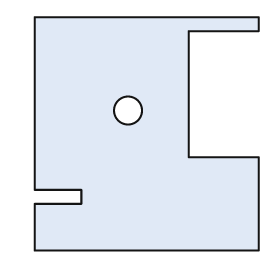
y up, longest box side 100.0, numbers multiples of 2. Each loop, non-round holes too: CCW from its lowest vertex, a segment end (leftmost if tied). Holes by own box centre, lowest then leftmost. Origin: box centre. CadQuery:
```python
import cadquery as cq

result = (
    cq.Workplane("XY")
    .moveTo(-48.0, -50.0)
    .lineTo(48.0, -50.0)
    .lineTo(48.0, -10.0)
    .lineTo(18.0, -10.0)
    .lineTo(18.0, 44.0)
    .lineTo(48.0, 44.0)
    .lineTo(48.0, 50.0)
    .lineTo(-48.0, 50.0)
    .lineTo(-48.0, -24.0)
    .lineTo(-28.0, -24.0)
    .lineTo(-28.0, -30.0)
    .lineTo(-48.0, -30.0)
    .close()
    .moveTo(-8.0, 10.0)
    .circle(6.0)
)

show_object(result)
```